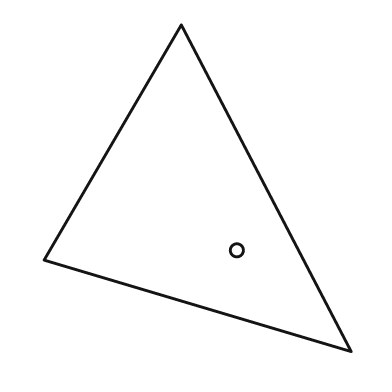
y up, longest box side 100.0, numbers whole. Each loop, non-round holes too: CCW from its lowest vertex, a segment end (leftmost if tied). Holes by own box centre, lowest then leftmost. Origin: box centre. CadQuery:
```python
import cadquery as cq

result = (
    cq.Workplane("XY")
    .moveTo(47.0, -50.0)
    .lineTo(-5.0, 50.0)
    .lineTo(-47.0, -22.0)
    .close()
    .moveTo(12.0, -19.0)
    .circle(2.0)
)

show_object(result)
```